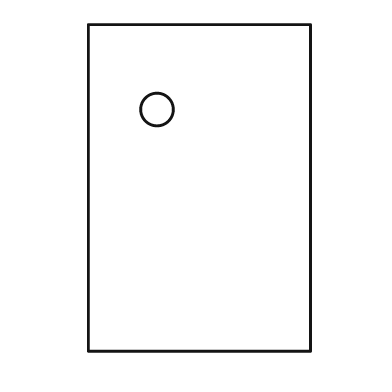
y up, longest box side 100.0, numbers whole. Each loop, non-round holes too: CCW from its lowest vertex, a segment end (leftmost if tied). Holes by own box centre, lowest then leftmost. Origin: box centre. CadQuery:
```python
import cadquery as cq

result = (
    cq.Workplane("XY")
    .moveTo(-34.0, -50.0)
    .lineTo(34.0, -50.0)
    .lineTo(34.0, 50.0)
    .lineTo(-34.0, 50.0)
    .close()
    .moveTo(-13.0, 24.0)
    .circle(5.0)
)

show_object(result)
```